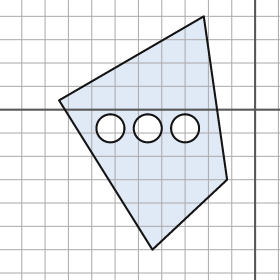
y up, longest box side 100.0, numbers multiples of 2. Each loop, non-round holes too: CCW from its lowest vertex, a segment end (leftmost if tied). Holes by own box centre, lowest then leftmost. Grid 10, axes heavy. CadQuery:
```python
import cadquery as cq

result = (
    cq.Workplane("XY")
    .moveTo(-44.0, -60.0)
    .lineTo(-12.0, -30.0)
    .lineTo(-22.0, 40.0)
    .lineTo(-84.0, 4.0)
    .close()
    .moveTo(-62.0, -8.0)
    .circle(6.0)
    .moveTo(-46.0, -8.0)
    .circle(6.0)
    .moveTo(-30.0, -8.0)
    .circle(6.0)
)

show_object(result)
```